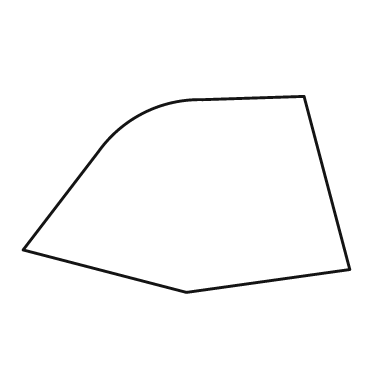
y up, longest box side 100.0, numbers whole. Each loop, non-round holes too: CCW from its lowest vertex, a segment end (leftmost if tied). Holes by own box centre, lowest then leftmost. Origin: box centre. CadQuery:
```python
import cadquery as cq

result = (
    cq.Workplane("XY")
    .moveTo(0.0, -30.0)
    .lineTo(50.0, -23.0)
    .lineTo(36.0, 30.0)
    .lineTo(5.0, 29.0)
    .threePointArc((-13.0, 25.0), (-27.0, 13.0))
    .lineTo(-50.0, -17.0)
    .close()
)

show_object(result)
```